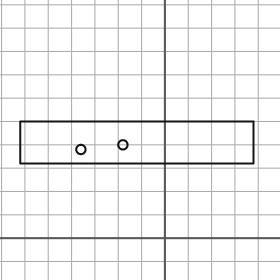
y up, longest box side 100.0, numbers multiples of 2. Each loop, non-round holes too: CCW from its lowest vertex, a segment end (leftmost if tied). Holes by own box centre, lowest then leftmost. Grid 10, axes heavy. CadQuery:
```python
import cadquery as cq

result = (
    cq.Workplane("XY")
    .moveTo(-62.0, 32.0)
    .lineTo(38.0, 32.0)
    .lineTo(38.0, 50.0)
    .lineTo(-62.0, 50.0)
    .close()
    .moveTo(-36.0, 38.0)
    .circle(2.0)
    .moveTo(-18.0, 40.0)
    .circle(2.0)
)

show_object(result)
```